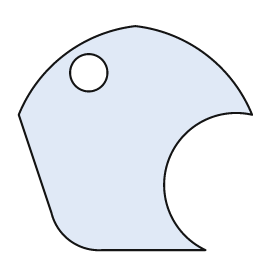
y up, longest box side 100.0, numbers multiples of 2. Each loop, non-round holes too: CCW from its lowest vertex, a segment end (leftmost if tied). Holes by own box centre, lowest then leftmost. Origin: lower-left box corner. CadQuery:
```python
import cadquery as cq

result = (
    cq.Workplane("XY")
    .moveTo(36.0, 0.0)
    .lineTo(80.0, 0.0)
    .threePointArc((64.0, 38.0), (100.0, 58.0))
    .threePointArc((80.0, 84.0), (50.0, 96.0))
    .threePointArc((20.0, 84.0), (0.0, 58.0))
    .lineTo(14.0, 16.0)
    .threePointArc((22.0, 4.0), (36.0, 0.0))
    .close()
    .moveTo(30.0, 76.0)
    .circle(8.0)
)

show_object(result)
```